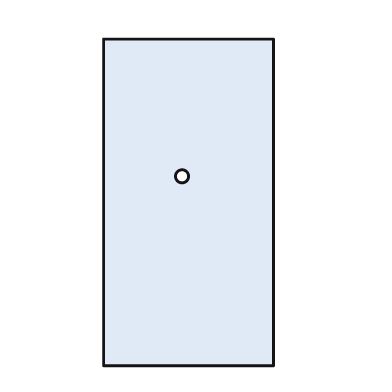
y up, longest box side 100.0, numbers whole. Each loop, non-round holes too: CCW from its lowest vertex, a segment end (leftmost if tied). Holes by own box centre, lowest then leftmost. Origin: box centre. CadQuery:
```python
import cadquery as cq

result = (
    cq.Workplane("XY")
    .moveTo(-26.0, -50.0)
    .lineTo(26.0, -50.0)
    .lineTo(26.0, 50.0)
    .lineTo(-26.0, 50.0)
    .close()
    .moveTo(-2.0, 8.0)
    .circle(2.0)
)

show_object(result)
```